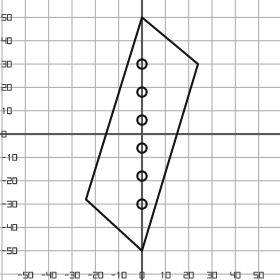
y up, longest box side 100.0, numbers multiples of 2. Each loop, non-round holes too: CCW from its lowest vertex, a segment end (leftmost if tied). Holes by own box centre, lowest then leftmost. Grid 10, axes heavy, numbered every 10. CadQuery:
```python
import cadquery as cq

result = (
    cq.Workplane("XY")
    .moveTo(0.0, -50.0)
    .lineTo(24.0, 30.0)
    .lineTo(0.0, 50.0)
    .lineTo(-24.0, -28.0)
    .close()
    .moveTo(0.0, -30.0)
    .circle(2.0)
    .moveTo(0.0, -18.0)
    .circle(2.0)
    .moveTo(0.0, -6.0)
    .circle(2.0)
    .moveTo(0.0, 6.0)
    .circle(2.0)
    .moveTo(0.0, 18.0)
    .circle(2.0)
    .moveTo(0.0, 30.0)
    .circle(2.0)
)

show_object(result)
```